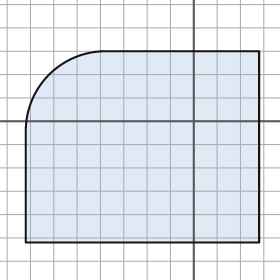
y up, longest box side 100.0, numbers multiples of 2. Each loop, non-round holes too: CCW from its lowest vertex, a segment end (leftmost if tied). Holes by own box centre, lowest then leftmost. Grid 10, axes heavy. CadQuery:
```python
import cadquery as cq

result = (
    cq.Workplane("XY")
    .moveTo(-72.0, -52.0)
    .lineTo(28.0, -52.0)
    .lineTo(28.0, 30.0)
    .lineTo(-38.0, 30.0)
    .threePointArc((-62.0, 20.0), (-72.0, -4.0))
    .close()
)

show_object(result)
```